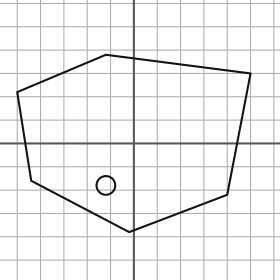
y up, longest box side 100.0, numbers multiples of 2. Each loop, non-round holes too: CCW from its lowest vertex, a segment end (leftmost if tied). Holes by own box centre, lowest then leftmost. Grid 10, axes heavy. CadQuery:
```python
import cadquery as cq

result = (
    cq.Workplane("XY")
    .moveTo(-2.0, -38.0)
    .lineTo(40.0, -22.0)
    .lineTo(50.0, 30.0)
    .lineTo(-12.0, 38.0)
    .lineTo(-50.0, 22.0)
    .lineTo(-44.0, -16.0)
    .close()
    .moveTo(-12.0, -18.0)
    .circle(4.0)
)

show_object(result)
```